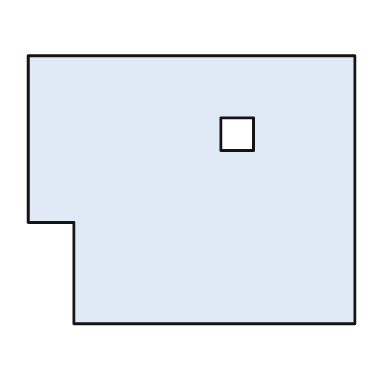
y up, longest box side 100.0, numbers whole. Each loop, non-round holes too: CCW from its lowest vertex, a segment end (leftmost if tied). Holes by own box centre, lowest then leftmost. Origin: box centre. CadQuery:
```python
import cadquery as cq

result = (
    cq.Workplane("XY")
    .moveTo(-36.0, -41.0)
    .lineTo(50.0, -41.0)
    .lineTo(50.0, 41.0)
    .lineTo(-50.0, 41.0)
    .lineTo(-50.0, -10.0)
    .lineTo(-36.0, -10.0)
    .close()
    .moveTo(9.0, 12.0)
    .lineTo(19.0, 12.0)
    .lineTo(19.0, 22.0)
    .lineTo(9.0, 22.0)
    .close()
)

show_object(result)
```